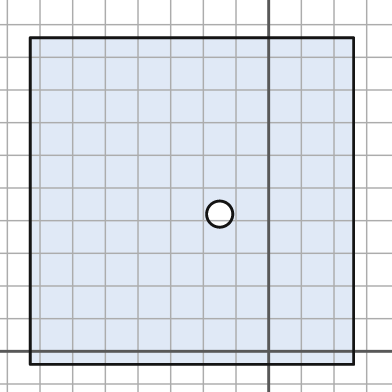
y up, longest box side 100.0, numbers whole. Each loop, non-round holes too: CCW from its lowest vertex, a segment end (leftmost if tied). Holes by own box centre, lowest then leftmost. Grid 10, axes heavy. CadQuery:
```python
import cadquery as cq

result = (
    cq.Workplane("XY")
    .moveTo(-73.0, -4.0)
    .lineTo(26.0, -4.0)
    .lineTo(26.0, 96.0)
    .lineTo(-73.0, 96.0)
    .close()
    .moveTo(-15.0, 42.0)
    .circle(4.0)
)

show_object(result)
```